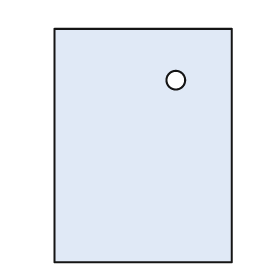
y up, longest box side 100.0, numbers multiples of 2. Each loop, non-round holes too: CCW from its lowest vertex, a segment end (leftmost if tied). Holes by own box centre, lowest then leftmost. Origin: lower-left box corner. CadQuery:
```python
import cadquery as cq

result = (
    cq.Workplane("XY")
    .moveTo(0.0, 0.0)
    .lineTo(76.0, 0.0)
    .lineTo(76.0, 100.0)
    .lineTo(0.0, 100.0)
    .close()
    .moveTo(52.0, 78.0)
    .circle(4.0)
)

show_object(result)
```